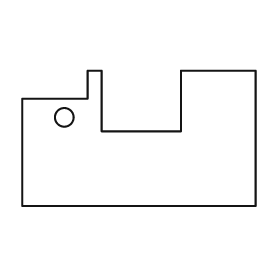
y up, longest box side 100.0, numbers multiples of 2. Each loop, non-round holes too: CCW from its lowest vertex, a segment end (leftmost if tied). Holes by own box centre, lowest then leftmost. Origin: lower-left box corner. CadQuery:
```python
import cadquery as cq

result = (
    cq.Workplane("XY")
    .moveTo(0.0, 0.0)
    .lineTo(100.0, 0.0)
    .lineTo(100.0, 58.0)
    .lineTo(68.0, 58.0)
    .lineTo(68.0, 32.0)
    .lineTo(34.0, 32.0)
    .lineTo(34.0, 58.0)
    .lineTo(28.0, 58.0)
    .lineTo(28.0, 46.0)
    .lineTo(0.0, 46.0)
    .close()
    .moveTo(18.0, 38.0)
    .circle(4.0)
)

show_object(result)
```